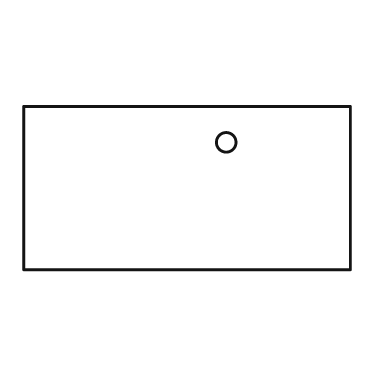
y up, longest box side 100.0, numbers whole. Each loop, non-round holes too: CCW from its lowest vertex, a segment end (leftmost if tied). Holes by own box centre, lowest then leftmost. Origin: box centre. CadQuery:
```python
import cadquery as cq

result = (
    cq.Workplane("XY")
    .moveTo(-50.0, -25.0)
    .lineTo(50.0, -25.0)
    .lineTo(50.0, 25.0)
    .lineTo(-50.0, 25.0)
    .close()
    .moveTo(12.0, 14.0)
    .circle(3.0)
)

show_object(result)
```